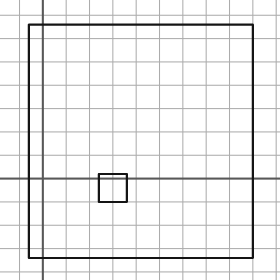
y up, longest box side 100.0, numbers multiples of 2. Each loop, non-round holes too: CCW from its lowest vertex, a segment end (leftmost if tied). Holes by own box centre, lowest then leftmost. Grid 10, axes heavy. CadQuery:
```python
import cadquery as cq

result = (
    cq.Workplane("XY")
    .moveTo(-6.0, -34.0)
    .lineTo(90.0, -34.0)
    .lineTo(90.0, 66.0)
    .lineTo(-6.0, 66.0)
    .close()
    .moveTo(24.0, -10.0)
    .lineTo(36.0, -10.0)
    .lineTo(36.0, 2.0)
    .lineTo(24.0, 2.0)
    .close()
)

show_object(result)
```